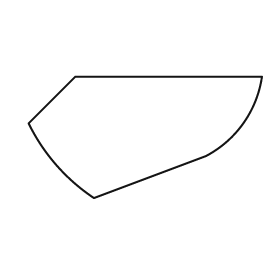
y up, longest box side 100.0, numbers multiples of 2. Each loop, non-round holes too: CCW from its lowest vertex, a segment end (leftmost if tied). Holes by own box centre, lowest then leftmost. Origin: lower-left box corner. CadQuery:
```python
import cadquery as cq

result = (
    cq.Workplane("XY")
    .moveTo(28.0, 0.0)
    .lineTo(76.0, 18.0)
    .threePointArc((92.0, 32.0), (100.0, 52.0))
    .lineTo(20.0, 52.0)
    .lineTo(0.0, 32.0)
    .threePointArc((12.0, 14.0), (28.0, 0.0))
    .close()
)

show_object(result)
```